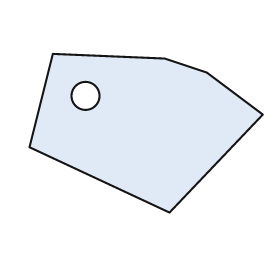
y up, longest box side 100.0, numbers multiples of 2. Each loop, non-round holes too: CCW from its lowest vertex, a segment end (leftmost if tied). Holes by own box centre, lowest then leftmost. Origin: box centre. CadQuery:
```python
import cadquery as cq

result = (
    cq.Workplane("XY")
    .moveTo(10.0, -34.0)
    .lineTo(50.0, 8.0)
    .lineTo(26.0, 26.0)
    .lineTo(8.0, 32.0)
    .lineTo(-40.0, 34.0)
    .lineTo(-50.0, -6.0)
    .close()
    .moveTo(-26.0, 16.0)
    .circle(6.0)
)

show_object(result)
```